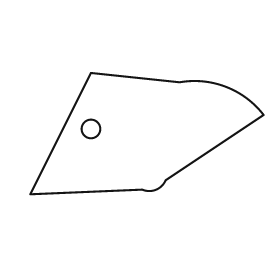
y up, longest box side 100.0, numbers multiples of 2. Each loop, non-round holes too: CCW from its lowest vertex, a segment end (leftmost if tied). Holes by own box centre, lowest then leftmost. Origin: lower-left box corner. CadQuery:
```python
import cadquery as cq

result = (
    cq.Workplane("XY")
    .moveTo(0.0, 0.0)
    .lineTo(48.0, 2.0)
    .threePointArc((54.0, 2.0), (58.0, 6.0))
    .lineTo(100.0, 34.0)
    .threePointArc((84.0, 46.0), (64.0, 48.0))
    .lineTo(26.0, 52.0)
    .close()
    .moveTo(26.0, 28.0)
    .circle(4.0)
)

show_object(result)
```